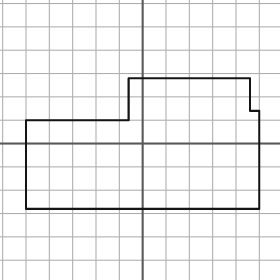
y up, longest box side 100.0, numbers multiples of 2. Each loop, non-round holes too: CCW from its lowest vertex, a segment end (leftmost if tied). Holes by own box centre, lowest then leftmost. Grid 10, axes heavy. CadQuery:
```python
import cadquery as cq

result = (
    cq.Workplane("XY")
    .moveTo(-50.0, -28.0)
    .lineTo(50.0, -28.0)
    .lineTo(50.0, 14.0)
    .lineTo(46.0, 14.0)
    .lineTo(46.0, 28.0)
    .lineTo(-6.0, 28.0)
    .lineTo(-6.0, 10.0)
    .lineTo(-50.0, 10.0)
    .close()
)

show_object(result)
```